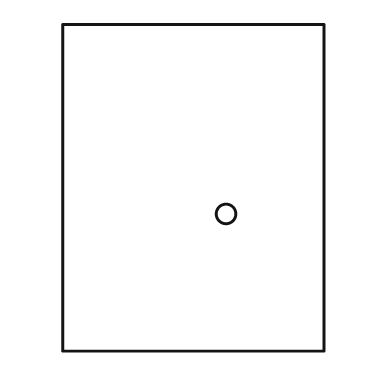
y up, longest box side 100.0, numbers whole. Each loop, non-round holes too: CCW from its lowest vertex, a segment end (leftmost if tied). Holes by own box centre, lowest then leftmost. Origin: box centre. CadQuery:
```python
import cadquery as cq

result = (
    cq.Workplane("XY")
    .moveTo(-40.0, -50.0)
    .lineTo(40.0, -50.0)
    .lineTo(40.0, 50.0)
    .lineTo(-40.0, 50.0)
    .close()
    .moveTo(10.0, -8.0)
    .circle(3.0)
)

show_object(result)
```